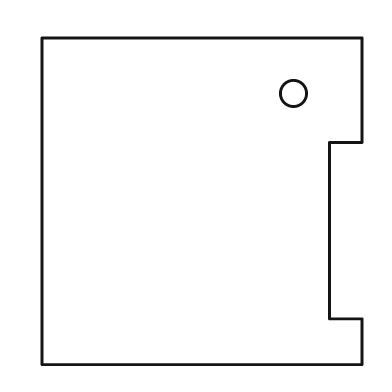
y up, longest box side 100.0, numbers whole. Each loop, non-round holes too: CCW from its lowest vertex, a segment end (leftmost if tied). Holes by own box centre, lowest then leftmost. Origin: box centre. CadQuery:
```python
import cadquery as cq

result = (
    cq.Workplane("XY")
    .moveTo(-49.0, -50.0)
    .lineTo(49.0, -50.0)
    .lineTo(49.0, -36.0)
    .lineTo(39.0, -36.0)
    .lineTo(39.0, 18.0)
    .lineTo(49.0, 18.0)
    .lineTo(49.0, 50.0)
    .lineTo(-49.0, 50.0)
    .close()
    .moveTo(28.0, 33.0)
    .circle(4.0)
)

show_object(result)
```